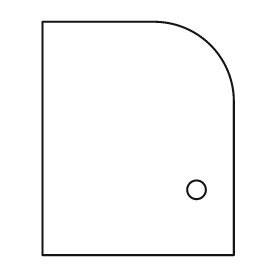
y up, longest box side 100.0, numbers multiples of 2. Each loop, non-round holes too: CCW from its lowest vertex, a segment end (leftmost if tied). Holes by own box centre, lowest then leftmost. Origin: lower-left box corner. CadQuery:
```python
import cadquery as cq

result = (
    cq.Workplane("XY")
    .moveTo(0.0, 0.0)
    .lineTo(82.0, 0.0)
    .lineTo(82.0, 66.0)
    .threePointArc((72.0, 90.0), (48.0, 100.0))
    .lineTo(0.0, 100.0)
    .close()
    .moveTo(66.0, 28.0)
    .circle(4.0)
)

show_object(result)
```